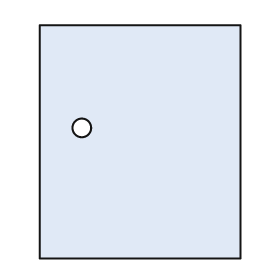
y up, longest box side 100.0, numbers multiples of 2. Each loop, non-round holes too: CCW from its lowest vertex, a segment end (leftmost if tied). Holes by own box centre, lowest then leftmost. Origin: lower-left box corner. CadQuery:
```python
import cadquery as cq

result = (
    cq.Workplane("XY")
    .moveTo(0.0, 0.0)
    .lineTo(86.0, 0.0)
    .lineTo(86.0, 100.0)
    .lineTo(0.0, 100.0)
    .close()
    .moveTo(18.0, 56.0)
    .circle(4.0)
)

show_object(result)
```